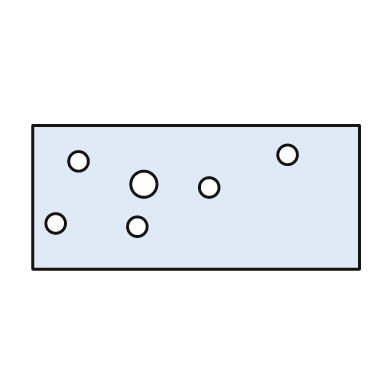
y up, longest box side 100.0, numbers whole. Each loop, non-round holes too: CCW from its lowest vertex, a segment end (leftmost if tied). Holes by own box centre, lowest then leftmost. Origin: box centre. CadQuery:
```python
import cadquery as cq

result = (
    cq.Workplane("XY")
    .moveTo(-50.0, -22.0)
    .lineTo(50.0, -22.0)
    .lineTo(50.0, 22.0)
    .lineTo(-50.0, 22.0)
    .close()
    .moveTo(-18.0, -9.0)
    .circle(3.0)
    .moveTo(-43.0, -8.0)
    .circle(3.0)
    .moveTo(4.0, 3.0)
    .circle(3.0)
    .moveTo(-16.0, 4.0)
    .circle(4.0)
    .moveTo(-36.0, 11.0)
    .circle(3.0)
    .moveTo(28.0, 13.0)
    .circle(3.0)
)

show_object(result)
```